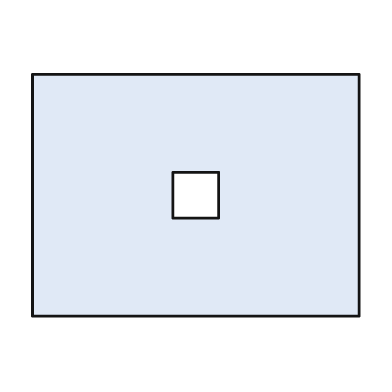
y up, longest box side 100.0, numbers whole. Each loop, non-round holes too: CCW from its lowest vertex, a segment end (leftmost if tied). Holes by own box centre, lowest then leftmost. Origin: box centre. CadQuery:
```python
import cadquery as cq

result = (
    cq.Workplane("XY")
    .moveTo(-50.0, -37.0)
    .lineTo(50.0, -37.0)
    .lineTo(50.0, 37.0)
    .lineTo(-50.0, 37.0)
    .close()
    .moveTo(-7.0, -7.0)
    .lineTo(7.0, -7.0)
    .lineTo(7.0, 7.0)
    .lineTo(-7.0, 7.0)
    .close()
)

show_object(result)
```